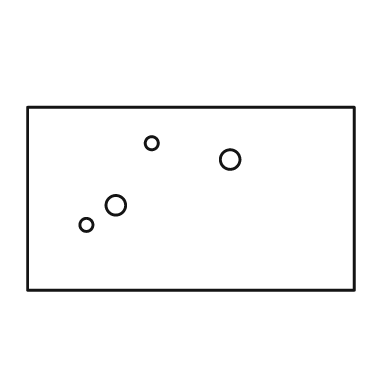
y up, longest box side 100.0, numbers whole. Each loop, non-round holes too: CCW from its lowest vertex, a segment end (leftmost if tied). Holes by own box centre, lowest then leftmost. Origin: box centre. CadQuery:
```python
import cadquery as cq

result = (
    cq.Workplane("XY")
    .moveTo(-50.0, -28.0)
    .lineTo(50.0, -28.0)
    .lineTo(50.0, 28.0)
    .lineTo(-50.0, 28.0)
    .close()
    .moveTo(-32.0, -8.0)
    .circle(2.0)
    .moveTo(-23.0, -2.0)
    .circle(3.0)
    .moveTo(12.0, 12.0)
    .circle(3.0)
    .moveTo(-12.0, 17.0)
    .circle(2.0)
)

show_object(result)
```